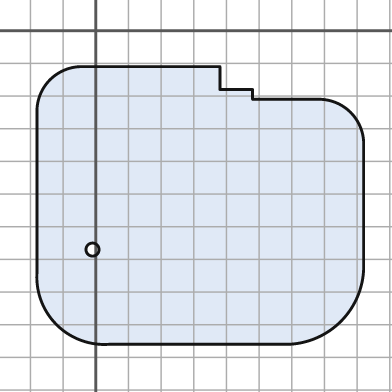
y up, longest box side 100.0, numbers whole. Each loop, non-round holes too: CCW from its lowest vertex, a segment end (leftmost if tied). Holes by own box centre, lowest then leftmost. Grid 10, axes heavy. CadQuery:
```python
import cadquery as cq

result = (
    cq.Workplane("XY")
    .moveTo(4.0, -96.0)
    .lineTo(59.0, -96.0)
    .threePointArc((75.0, -89.0), (82.0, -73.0))
    .lineTo(82.0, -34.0)
    .threePointArc((78.0, -25.0), (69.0, -21.0))
    .lineTo(48.0, -21.0)
    .lineTo(48.0, -18.0)
    .lineTo(38.0, -18.0)
    .lineTo(38.0, -11.0)
    .lineTo(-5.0, -11.0)
    .threePointArc((-14.0, -15.0), (-18.0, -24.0))
    .lineTo(-18.0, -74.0)
    .threePointArc((-12.0, -90.0), (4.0, -96.0))
    .close()
    .moveTo(-1.0, -67.0)
    .circle(2.0)
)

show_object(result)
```